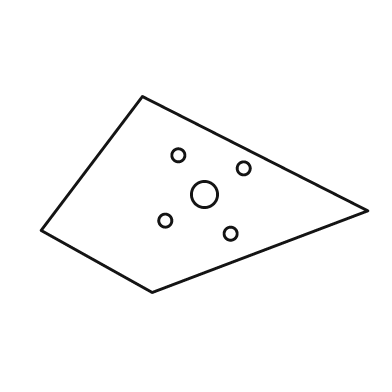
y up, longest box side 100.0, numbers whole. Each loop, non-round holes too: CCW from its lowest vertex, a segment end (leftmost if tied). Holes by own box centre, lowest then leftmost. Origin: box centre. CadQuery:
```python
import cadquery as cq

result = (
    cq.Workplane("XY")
    .moveTo(-16.0, -30.0)
    .lineTo(50.0, -5.0)
    .lineTo(-19.0, 30.0)
    .lineTo(-50.0, -11.0)
    .close()
    .moveTo(8.0, -12.0)
    .circle(2.0)
    .moveTo(-12.0, -8.0)
    .circle(2.0)
    .moveTo(0.0, 0.0)
    .circle(4.0)
    .moveTo(12.0, 8.0)
    .circle(2.0)
    .moveTo(-8.0, 12.0)
    .circle(2.0)
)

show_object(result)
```